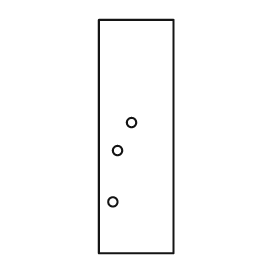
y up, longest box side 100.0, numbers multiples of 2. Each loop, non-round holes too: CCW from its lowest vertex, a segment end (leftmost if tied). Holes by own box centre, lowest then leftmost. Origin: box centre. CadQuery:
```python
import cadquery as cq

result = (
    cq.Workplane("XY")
    .moveTo(-16.0, -50.0)
    .lineTo(16.0, -50.0)
    .lineTo(16.0, 50.0)
    .lineTo(-16.0, 50.0)
    .close()
    .moveTo(-10.0, -28.0)
    .circle(2.0)
    .moveTo(-8.0, -6.0)
    .circle(2.0)
    .moveTo(-2.0, 6.0)
    .circle(2.0)
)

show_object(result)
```